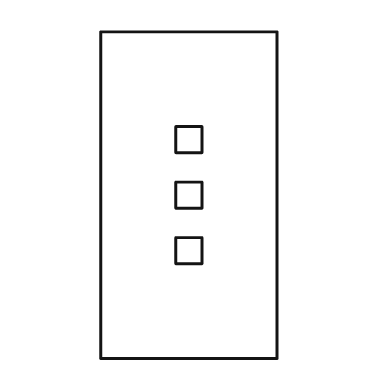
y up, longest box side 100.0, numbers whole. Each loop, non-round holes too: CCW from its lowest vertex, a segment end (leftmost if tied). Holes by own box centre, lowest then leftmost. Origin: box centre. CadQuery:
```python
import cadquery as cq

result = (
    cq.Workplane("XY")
    .moveTo(-27.0, -50.0)
    .lineTo(27.0, -50.0)
    .lineTo(27.0, 50.0)
    .lineTo(-27.0, 50.0)
    .close()
    .moveTo(-4.0, -21.0)
    .lineTo(4.0, -21.0)
    .lineTo(4.0, -13.0)
    .lineTo(-4.0, -13.0)
    .close()
    .moveTo(-4.0, -4.0)
    .lineTo(4.0, -4.0)
    .lineTo(4.0, 4.0)
    .lineTo(-4.0, 4.0)
    .close()
    .moveTo(-4.0, 13.0)
    .lineTo(4.0, 13.0)
    .lineTo(4.0, 21.0)
    .lineTo(-4.0, 21.0)
    .close()
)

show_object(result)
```